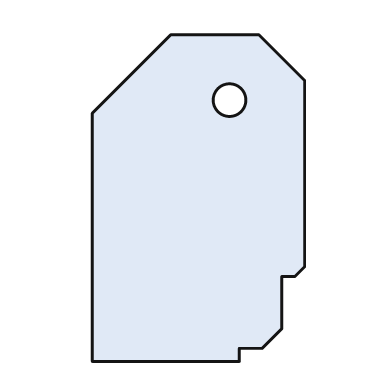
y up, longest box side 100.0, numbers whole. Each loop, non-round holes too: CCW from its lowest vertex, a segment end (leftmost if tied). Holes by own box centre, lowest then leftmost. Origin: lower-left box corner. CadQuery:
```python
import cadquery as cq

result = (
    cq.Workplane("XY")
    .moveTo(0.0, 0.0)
    .lineTo(45.0, 0.0)
    .lineTo(45.0, 4.0)
    .lineTo(52.0, 4.0)
    .lineTo(58.0, 10.0)
    .lineTo(58.0, 26.0)
    .lineTo(62.0, 26.0)
    .lineTo(65.0, 29.0)
    .lineTo(65.0, 86.0)
    .lineTo(51.0, 100.0)
    .lineTo(24.0, 100.0)
    .lineTo(0.0, 76.0)
    .close()
    .moveTo(42.0, 80.0)
    .circle(5.0)
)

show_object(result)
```